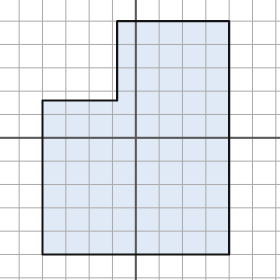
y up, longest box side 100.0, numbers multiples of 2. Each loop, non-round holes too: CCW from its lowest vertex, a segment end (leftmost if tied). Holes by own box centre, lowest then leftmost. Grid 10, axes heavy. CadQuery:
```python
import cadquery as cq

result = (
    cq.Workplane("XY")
    .moveTo(-40.0, -50.0)
    .lineTo(40.0, -50.0)
    .lineTo(40.0, 50.0)
    .lineTo(-8.0, 50.0)
    .lineTo(-8.0, 16.0)
    .lineTo(-40.0, 16.0)
    .close()
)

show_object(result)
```